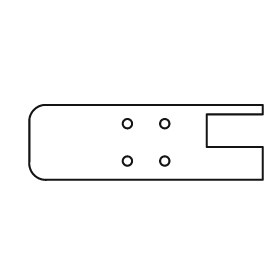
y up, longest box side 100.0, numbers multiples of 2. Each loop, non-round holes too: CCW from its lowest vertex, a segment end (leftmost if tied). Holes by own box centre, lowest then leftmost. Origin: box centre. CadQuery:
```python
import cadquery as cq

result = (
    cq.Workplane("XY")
    .moveTo(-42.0, -16.0)
    .lineTo(50.0, -16.0)
    .lineTo(50.0, -2.0)
    .lineTo(26.0, -2.0)
    .lineTo(26.0, 12.0)
    .lineTo(50.0, 12.0)
    .lineTo(50.0, 16.0)
    .lineTo(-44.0, 16.0)
    .threePointArc((-48.0, 14.0), (-50.0, 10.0))
    .lineTo(-50.0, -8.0)
    .threePointArc((-48.0, -14.0), (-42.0, -16.0))
    .close()
    .moveTo(-8.0, -8.0)
    .circle(2.0)
    .moveTo(8.0, -8.0)
    .circle(2.0)
    .moveTo(-8.0, 8.0)
    .circle(2.0)
    .moveTo(8.0, 8.0)
    .circle(2.0)
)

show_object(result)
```